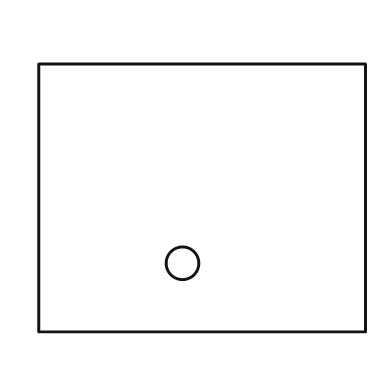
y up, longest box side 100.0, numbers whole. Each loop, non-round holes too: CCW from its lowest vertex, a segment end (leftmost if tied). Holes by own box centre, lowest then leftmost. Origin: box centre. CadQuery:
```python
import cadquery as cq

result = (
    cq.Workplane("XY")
    .moveTo(-50.0, -41.0)
    .lineTo(50.0, -41.0)
    .lineTo(50.0, 41.0)
    .lineTo(-50.0, 41.0)
    .close()
    .moveTo(-6.0, -20.0)
    .circle(5.0)
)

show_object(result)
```